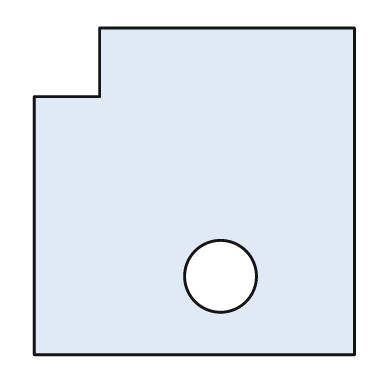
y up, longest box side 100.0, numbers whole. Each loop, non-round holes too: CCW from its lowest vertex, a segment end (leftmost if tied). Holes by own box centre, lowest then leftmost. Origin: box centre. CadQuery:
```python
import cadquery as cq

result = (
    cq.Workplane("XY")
    .moveTo(-49.0, -50.0)
    .lineTo(49.0, -50.0)
    .lineTo(49.0, 50.0)
    .lineTo(-29.0, 50.0)
    .lineTo(-29.0, 29.0)
    .lineTo(-49.0, 29.0)
    .close()
    .moveTo(8.0, -26.0)
    .circle(11.0)
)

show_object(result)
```